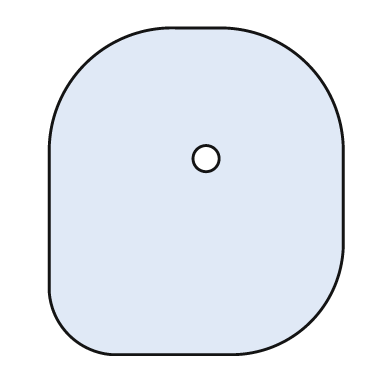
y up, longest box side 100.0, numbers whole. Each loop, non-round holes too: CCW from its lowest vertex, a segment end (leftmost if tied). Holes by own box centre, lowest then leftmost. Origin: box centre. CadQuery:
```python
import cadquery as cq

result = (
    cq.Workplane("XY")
    .moveTo(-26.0, -50.0)
    .lineTo(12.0, -50.0)
    .threePointArc((35.0, -40.0), (45.0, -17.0))
    .lineTo(45.0, 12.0)
    .threePointArc((34.0, 39.0), (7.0, 50.0))
    .lineTo(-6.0, 50.0)
    .threePointArc((-34.0, 39.0), (-45.0, 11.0))
    .lineTo(-45.0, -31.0)
    .threePointArc((-39.0, -44.0), (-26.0, -50.0))
    .close()
    .moveTo(3.0, 10.0)
    .circle(4.0)
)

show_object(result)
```